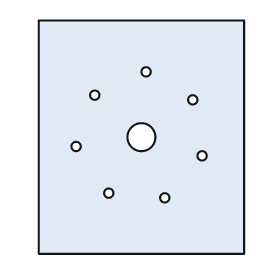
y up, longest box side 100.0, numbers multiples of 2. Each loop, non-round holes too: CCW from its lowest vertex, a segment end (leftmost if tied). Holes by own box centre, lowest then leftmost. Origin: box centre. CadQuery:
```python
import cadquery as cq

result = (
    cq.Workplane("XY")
    .moveTo(-44.0, -50.0)
    .lineTo(44.0, -50.0)
    .lineTo(44.0, 50.0)
    .lineTo(-44.0, 50.0)
    .close()
    .moveTo(10.0, -26.0)
    .circle(2.0)
    .moveTo(-14.0, -24.0)
    .circle(2.0)
    .moveTo(26.0, -8.0)
    .circle(2.0)
    .moveTo(-28.0, -4.0)
    .circle(2.0)
    .moveTo(0.0, 0.0)
    .circle(6.0)
    .moveTo(22.0, 16.0)
    .circle(2.0)
    .moveTo(-20.0, 18.0)
    .circle(2.0)
    .moveTo(2.0, 28.0)
    .circle(2.0)
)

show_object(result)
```